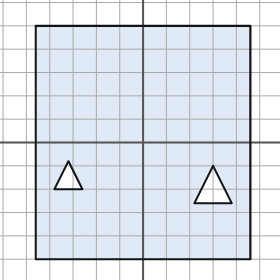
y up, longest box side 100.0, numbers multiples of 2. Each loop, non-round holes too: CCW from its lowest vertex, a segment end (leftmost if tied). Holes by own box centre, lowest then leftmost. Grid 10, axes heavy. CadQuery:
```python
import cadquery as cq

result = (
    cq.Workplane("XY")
    .moveTo(-46.0, -50.0)
    .lineTo(46.0, -50.0)
    .lineTo(46.0, 50.0)
    .lineTo(-46.0, 50.0)
    .close()
    .moveTo(22.0, -26.0)
    .lineTo(38.0, -26.0)
    .lineTo(30.0, -10.0)
    .close()
    .moveTo(-38.0, -20.0)
    .lineTo(-26.0, -20.0)
    .lineTo(-32.0, -8.0)
    .close()
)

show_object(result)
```